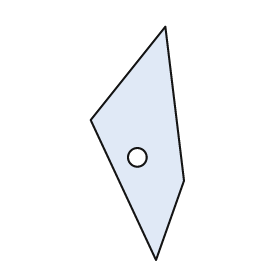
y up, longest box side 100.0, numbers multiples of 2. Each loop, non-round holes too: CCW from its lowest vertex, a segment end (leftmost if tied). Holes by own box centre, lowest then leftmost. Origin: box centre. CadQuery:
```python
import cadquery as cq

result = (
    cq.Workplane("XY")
    .moveTo(8.0, -50.0)
    .lineTo(20.0, -16.0)
    .lineTo(12.0, 50.0)
    .lineTo(-20.0, 10.0)
    .close()
    .moveTo(0.0, -6.0)
    .circle(4.0)
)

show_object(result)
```